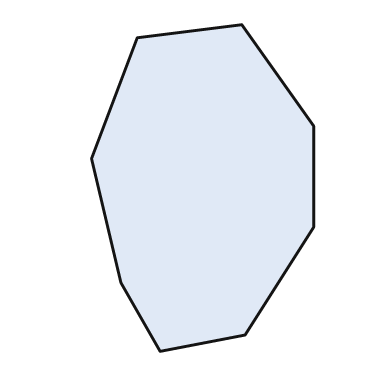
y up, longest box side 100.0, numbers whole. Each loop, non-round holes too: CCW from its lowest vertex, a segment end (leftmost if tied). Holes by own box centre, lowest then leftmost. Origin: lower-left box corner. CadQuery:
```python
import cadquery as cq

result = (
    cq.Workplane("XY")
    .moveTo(21.0, 0.0)
    .lineTo(47.0, 5.0)
    .lineTo(68.0, 38.0)
    .lineTo(68.0, 69.0)
    .lineTo(46.0, 100.0)
    .lineTo(14.0, 96.0)
    .lineTo(0.0, 59.0)
    .lineTo(9.0, 21.0)
    .close()
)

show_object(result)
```